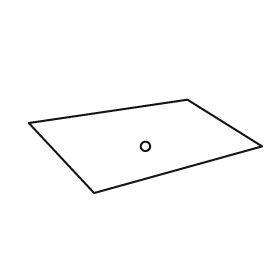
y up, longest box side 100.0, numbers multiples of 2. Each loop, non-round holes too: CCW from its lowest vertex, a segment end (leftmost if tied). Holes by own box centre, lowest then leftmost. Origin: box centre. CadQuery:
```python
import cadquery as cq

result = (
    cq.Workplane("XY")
    .moveTo(-22.0, -20.0)
    .lineTo(50.0, 0.0)
    .lineTo(18.0, 20.0)
    .lineTo(-50.0, 10.0)
    .close()
    .moveTo(0.0, 0.0)
    .circle(2.0)
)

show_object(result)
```